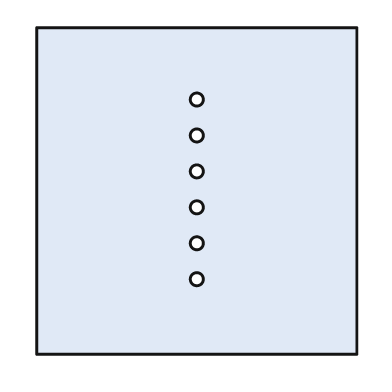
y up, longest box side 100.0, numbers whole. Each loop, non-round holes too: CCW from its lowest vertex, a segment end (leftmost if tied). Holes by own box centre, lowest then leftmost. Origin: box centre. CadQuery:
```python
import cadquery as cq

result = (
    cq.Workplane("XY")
    .moveTo(-49.0, -50.0)
    .lineTo(49.0, -50.0)
    .lineTo(49.0, 50.0)
    .lineTo(-49.0, 50.0)
    .close()
    .moveTo(0.0, -27.0)
    .circle(2.0)
    .moveTo(0.0, -16.0)
    .circle(2.0)
    .moveTo(0.0, -5.0)
    .circle(2.0)
    .moveTo(0.0, 6.0)
    .circle(2.0)
    .moveTo(0.0, 17.0)
    .circle(2.0)
    .moveTo(0.0, 28.0)
    .circle(2.0)
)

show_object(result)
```